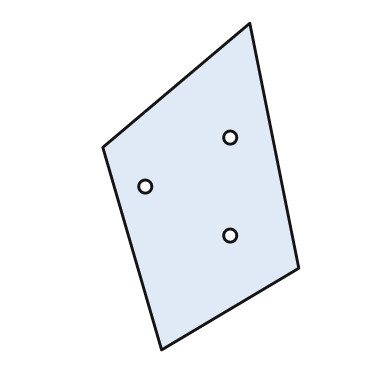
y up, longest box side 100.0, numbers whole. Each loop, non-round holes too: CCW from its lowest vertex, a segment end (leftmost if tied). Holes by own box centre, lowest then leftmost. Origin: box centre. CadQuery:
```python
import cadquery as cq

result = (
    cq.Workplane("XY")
    .moveTo(-12.0, -50.0)
    .lineTo(30.0, -25.0)
    .lineTo(15.0, 50.0)
    .lineTo(-30.0, 12.0)
    .close()
    .moveTo(9.0, -15.0)
    .circle(2.0)
    .moveTo(-17.0, 0.0)
    .circle(2.0)
    .moveTo(9.0, 15.0)
    .circle(2.0)
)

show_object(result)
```